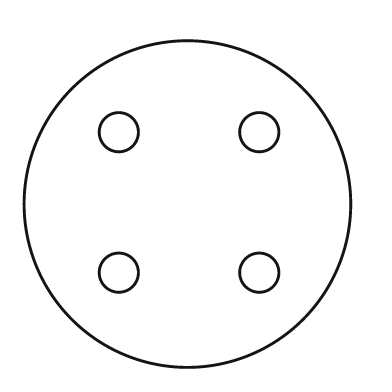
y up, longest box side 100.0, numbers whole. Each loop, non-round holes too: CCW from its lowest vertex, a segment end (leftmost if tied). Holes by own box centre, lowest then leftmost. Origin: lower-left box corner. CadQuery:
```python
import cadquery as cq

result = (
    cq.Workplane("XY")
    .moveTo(50.0, 50.0)
    .circle(50.0)
    .moveTo(29.0, 29.0)
    .circle(6.0)
    .moveTo(72.0, 29.0)
    .circle(6.0)
    .moveTo(29.0, 72.0)
    .circle(6.0)
    .moveTo(72.0, 72.0)
    .circle(6.0)
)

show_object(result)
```